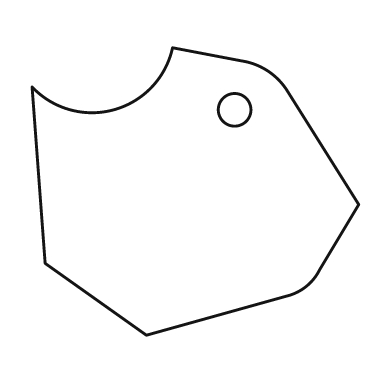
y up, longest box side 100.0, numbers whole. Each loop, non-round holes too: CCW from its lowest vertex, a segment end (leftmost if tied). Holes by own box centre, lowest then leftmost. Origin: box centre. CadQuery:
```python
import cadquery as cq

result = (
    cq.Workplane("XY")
    .moveTo(-15.0, -44.0)
    .lineTo(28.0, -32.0)
    .threePointArc((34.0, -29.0), (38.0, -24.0))
    .lineTo(50.0, -4.0)
    .lineTo(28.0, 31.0)
    .threePointArc((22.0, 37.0), (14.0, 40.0))
    .lineTo(-7.0, 44.0)
    .threePointArc((-25.0, 25.0), (-50.0, 32.0))
    .lineTo(-46.0, -22.0)
    .close()
    .moveTo(12.0, 25.0)
    .circle(5.0)
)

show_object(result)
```